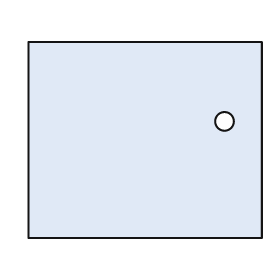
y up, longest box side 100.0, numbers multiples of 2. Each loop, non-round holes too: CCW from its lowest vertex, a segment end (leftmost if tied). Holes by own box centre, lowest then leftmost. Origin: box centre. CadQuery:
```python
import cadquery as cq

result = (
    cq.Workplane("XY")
    .moveTo(-50.0, -42.0)
    .lineTo(50.0, -42.0)
    .lineTo(50.0, 42.0)
    .lineTo(-50.0, 42.0)
    .close()
    .moveTo(34.0, 8.0)
    .circle(4.0)
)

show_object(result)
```